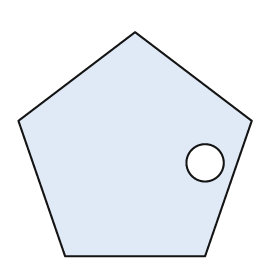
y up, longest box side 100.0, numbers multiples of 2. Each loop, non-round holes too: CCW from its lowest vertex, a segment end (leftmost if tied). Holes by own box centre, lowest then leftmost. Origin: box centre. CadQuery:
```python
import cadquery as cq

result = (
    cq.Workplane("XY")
    .moveTo(-30.0, -48.0)
    .lineTo(30.0, -48.0)
    .lineTo(50.0, 10.0)
    .lineTo(0.0, 48.0)
    .lineTo(-50.0, 10.0)
    .close()
    .moveTo(30.0, -8.0)
    .circle(8.0)
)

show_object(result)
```